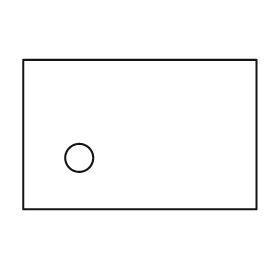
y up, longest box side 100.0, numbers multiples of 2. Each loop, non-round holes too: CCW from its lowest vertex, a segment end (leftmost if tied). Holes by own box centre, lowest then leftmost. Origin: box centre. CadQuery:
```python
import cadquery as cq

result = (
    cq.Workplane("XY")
    .moveTo(-50.0, -32.0)
    .lineTo(50.0, -32.0)
    .lineTo(50.0, 32.0)
    .lineTo(-50.0, 32.0)
    .close()
    .moveTo(-26.0, -10.0)
    .circle(6.0)
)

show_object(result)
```